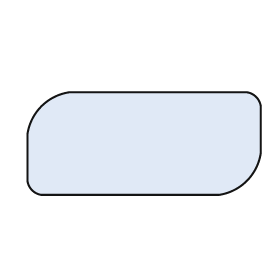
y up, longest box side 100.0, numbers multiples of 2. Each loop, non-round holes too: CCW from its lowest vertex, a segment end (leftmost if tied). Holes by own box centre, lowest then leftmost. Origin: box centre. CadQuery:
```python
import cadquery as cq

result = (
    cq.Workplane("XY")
    .moveTo(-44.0, -22.0)
    .lineTo(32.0, -22.0)
    .threePointArc((44.0, -16.0), (50.0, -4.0))
    .lineTo(50.0, 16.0)
    .threePointArc((48.0, 20.0), (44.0, 22.0))
    .lineTo(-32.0, 22.0)
    .threePointArc((-44.0, 16.0), (-50.0, 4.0))
    .lineTo(-50.0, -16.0)
    .threePointArc((-48.0, -20.0), (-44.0, -22.0))
    .close()
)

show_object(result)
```